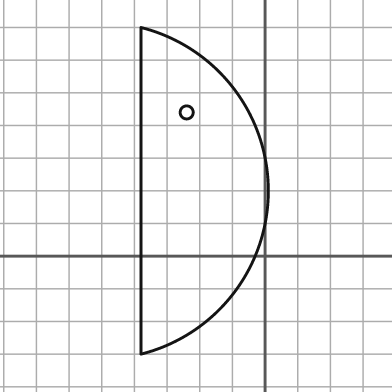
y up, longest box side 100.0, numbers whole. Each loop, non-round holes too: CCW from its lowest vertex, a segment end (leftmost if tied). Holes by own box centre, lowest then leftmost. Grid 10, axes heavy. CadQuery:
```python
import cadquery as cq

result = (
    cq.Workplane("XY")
    .moveTo(-38.0, -30.0)
    .threePointArc((1.0, 20.0), (-38.0, 70.0))
    .close()
    .moveTo(-24.0, 44.0)
    .circle(2.0)
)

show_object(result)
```